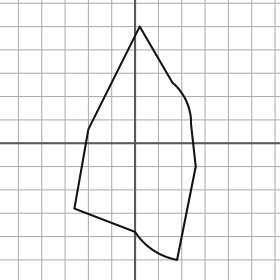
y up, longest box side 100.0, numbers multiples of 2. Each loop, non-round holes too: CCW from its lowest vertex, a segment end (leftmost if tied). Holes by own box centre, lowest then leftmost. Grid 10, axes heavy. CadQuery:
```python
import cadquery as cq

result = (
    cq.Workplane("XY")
    .moveTo(18.0, -50.0)
    .lineTo(26.0, -10.0)
    .lineTo(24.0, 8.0)
    .threePointArc((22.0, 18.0), (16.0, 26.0))
    .lineTo(2.0, 50.0)
    .lineTo(-20.0, 6.0)
    .lineTo(-26.0, -28.0)
    .lineTo(0.0, -38.0)
    .threePointArc((8.0, -46.0), (18.0, -50.0))
    .close()
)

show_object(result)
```